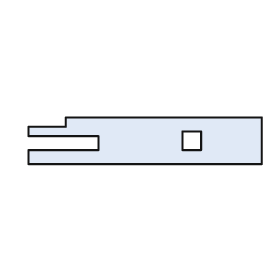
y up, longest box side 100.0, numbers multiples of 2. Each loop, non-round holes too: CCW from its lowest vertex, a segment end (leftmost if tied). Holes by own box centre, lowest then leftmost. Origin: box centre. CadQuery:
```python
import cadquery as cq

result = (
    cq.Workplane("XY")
    .moveTo(-50.0, -10.0)
    .lineTo(50.0, -10.0)
    .lineTo(50.0, 10.0)
    .lineTo(-34.0, 10.0)
    .lineTo(-34.0, 6.0)
    .lineTo(-50.0, 6.0)
    .lineTo(-50.0, 2.0)
    .lineTo(-20.0, 2.0)
    .lineTo(-20.0, -4.0)
    .lineTo(-50.0, -4.0)
    .close()
    .moveTo(16.0, -4.0)
    .lineTo(24.0, -4.0)
    .lineTo(24.0, 4.0)
    .lineTo(16.0, 4.0)
    .close()
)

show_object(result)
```